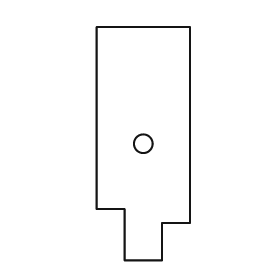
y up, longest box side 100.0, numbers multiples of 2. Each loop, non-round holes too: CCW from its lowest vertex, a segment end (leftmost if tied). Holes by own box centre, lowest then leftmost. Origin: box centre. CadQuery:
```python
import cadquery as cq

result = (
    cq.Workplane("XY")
    .moveTo(-8.0, -50.0)
    .lineTo(8.0, -50.0)
    .lineTo(8.0, -34.0)
    .lineTo(20.0, -34.0)
    .lineTo(20.0, 50.0)
    .lineTo(-20.0, 50.0)
    .lineTo(-20.0, -28.0)
    .lineTo(-8.0, -28.0)
    .close()
    .moveTo(0.0, 0.0)
    .circle(4.0)
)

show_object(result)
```